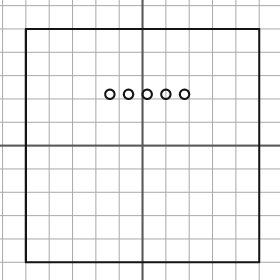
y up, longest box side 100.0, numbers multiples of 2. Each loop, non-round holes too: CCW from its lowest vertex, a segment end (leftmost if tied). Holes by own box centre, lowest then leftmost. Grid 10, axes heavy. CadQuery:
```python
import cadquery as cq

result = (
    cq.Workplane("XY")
    .moveTo(-50.0, -50.0)
    .lineTo(50.0, -50.0)
    .lineTo(50.0, 50.0)
    .lineTo(-50.0, 50.0)
    .close()
    .moveTo(-14.0, 22.0)
    .circle(2.0)
    .moveTo(-6.0, 22.0)
    .circle(2.0)
    .moveTo(2.0, 22.0)
    .circle(2.0)
    .moveTo(10.0, 22.0)
    .circle(2.0)
    .moveTo(18.0, 22.0)
    .circle(2.0)
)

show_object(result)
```